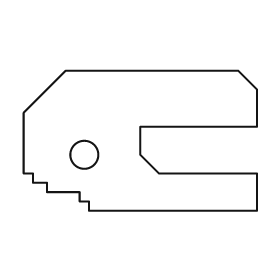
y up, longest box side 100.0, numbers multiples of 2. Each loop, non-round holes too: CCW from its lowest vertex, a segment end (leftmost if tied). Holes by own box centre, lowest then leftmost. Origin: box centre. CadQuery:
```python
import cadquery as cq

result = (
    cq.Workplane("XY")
    .moveTo(-22.0, -30.0)
    .lineTo(50.0, -30.0)
    .lineTo(50.0, -14.0)
    .lineTo(8.0, -14.0)
    .lineTo(0.0, -6.0)
    .lineTo(0.0, 6.0)
    .lineTo(50.0, 6.0)
    .lineTo(50.0, 22.0)
    .lineTo(42.0, 30.0)
    .lineTo(-32.0, 30.0)
    .lineTo(-50.0, 12.0)
    .lineTo(-50.0, -14.0)
    .lineTo(-46.0, -14.0)
    .lineTo(-46.0, -18.0)
    .lineTo(-40.0, -18.0)
    .lineTo(-40.0, -22.0)
    .lineTo(-26.0, -22.0)
    .lineTo(-26.0, -26.0)
    .lineTo(-22.0, -26.0)
    .close()
    .moveTo(-24.0, -6.0)
    .circle(6.0)
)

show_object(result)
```